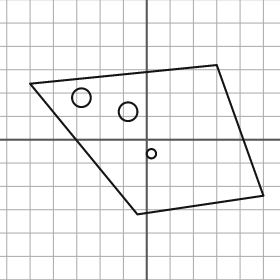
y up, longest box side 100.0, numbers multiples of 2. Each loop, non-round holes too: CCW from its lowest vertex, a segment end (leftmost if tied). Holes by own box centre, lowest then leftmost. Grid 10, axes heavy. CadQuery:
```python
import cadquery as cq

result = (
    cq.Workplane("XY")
    .moveTo(-4.0, -32.0)
    .lineTo(50.0, -24.0)
    .lineTo(30.0, 32.0)
    .lineTo(-50.0, 24.0)
    .close()
    .moveTo(2.0, -6.0)
    .circle(2.0)
    .moveTo(-8.0, 12.0)
    .circle(4.0)
    .moveTo(-28.0, 18.0)
    .circle(4.0)
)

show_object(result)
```